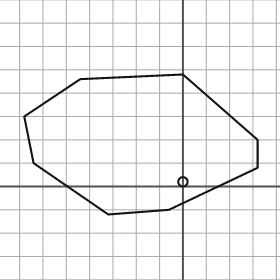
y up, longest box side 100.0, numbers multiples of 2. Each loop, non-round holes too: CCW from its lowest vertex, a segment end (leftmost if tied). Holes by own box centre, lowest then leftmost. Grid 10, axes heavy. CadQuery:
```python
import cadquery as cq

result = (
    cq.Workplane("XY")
    .moveTo(-32.0, -12.0)
    .lineTo(-6.0, -10.0)
    .lineTo(32.0, 8.0)
    .lineTo(32.0, 20.0)
    .lineTo(0.0, 48.0)
    .lineTo(-44.0, 46.0)
    .lineTo(-68.0, 30.0)
    .lineTo(-64.0, 10.0)
    .close()
    .moveTo(0.0, 2.0)
    .circle(2.0)
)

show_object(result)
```